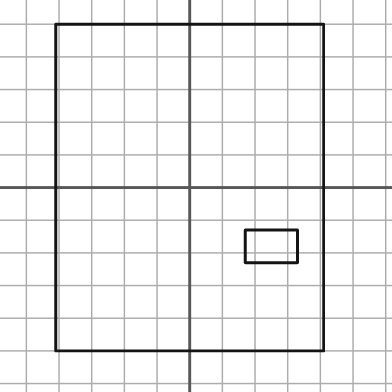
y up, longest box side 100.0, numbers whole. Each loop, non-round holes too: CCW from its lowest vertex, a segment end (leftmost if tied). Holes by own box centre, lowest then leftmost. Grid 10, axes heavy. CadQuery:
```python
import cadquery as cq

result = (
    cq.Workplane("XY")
    .moveTo(-41.0, -50.0)
    .lineTo(41.0, -50.0)
    .lineTo(41.0, 50.0)
    .lineTo(-41.0, 50.0)
    .close()
    .moveTo(17.0, -23.0)
    .lineTo(33.0, -23.0)
    .lineTo(33.0, -13.0)
    .lineTo(17.0, -13.0)
    .close()
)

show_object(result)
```